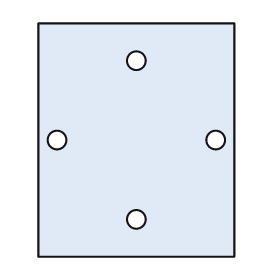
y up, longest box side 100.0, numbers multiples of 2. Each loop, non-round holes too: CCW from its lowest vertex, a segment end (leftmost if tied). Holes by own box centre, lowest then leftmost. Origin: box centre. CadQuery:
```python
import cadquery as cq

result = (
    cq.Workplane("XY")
    .moveTo(-42.0, -50.0)
    .lineTo(42.0, -50.0)
    .lineTo(42.0, 50.0)
    .lineTo(-42.0, 50.0)
    .close()
    .moveTo(0.0, -34.0)
    .circle(4.0)
    .moveTo(-34.0, 0.0)
    .circle(4.0)
    .moveTo(34.0, 0.0)
    .circle(4.0)
    .moveTo(0.0, 34.0)
    .circle(4.0)
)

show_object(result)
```